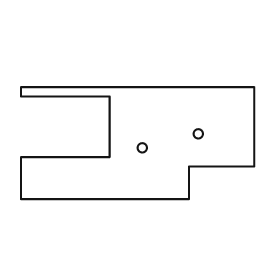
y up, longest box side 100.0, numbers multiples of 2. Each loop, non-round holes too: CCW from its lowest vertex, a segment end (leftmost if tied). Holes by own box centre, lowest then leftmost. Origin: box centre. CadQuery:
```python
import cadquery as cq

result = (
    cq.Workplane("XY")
    .moveTo(-50.0, -24.0)
    .lineTo(22.0, -24.0)
    .lineTo(22.0, -10.0)
    .lineTo(50.0, -10.0)
    .lineTo(50.0, 24.0)
    .lineTo(-50.0, 24.0)
    .lineTo(-50.0, 20.0)
    .lineTo(-12.0, 20.0)
    .lineTo(-12.0, -6.0)
    .lineTo(-50.0, -6.0)
    .close()
    .moveTo(2.0, -2.0)
    .circle(2.0)
    .moveTo(26.0, 4.0)
    .circle(2.0)
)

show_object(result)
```